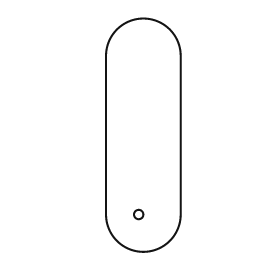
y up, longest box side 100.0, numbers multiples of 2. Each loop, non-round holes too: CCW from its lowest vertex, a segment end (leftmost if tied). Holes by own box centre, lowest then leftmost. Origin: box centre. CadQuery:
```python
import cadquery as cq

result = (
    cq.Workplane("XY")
    .moveTo(-16.0, -34.0)
    .threePointArc((0.0, -50.0), (16.0, -34.0))
    .lineTo(16.0, 34.0)
    .threePointArc((0.0, 50.0), (-16.0, 34.0))
    .close()
    .moveTo(-2.0, -34.0)
    .circle(2.0)
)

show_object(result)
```